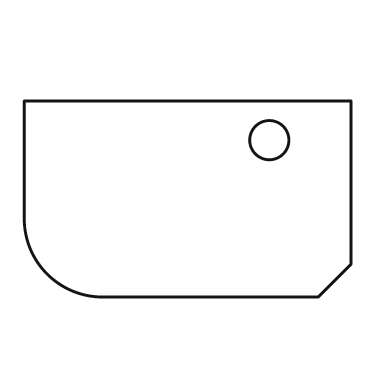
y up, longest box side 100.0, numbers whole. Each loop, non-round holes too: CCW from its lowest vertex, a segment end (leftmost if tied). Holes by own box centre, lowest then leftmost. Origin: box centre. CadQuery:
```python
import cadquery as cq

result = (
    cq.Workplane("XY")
    .moveTo(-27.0, -30.0)
    .lineTo(40.0, -30.0)
    .lineTo(50.0, -20.0)
    .lineTo(50.0, 30.0)
    .lineTo(-50.0, 30.0)
    .lineTo(-50.0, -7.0)
    .threePointArc((-43.0, -23.0), (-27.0, -30.0))
    .close()
    .moveTo(25.0, 18.0)
    .circle(6.0)
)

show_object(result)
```